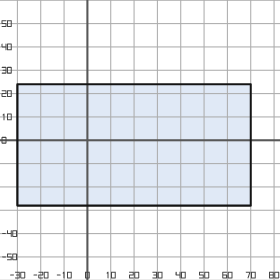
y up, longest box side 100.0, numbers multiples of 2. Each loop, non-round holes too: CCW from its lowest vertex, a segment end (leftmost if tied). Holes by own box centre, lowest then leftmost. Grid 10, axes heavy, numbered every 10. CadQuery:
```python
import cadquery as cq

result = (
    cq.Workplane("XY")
    .moveTo(-30.0, -28.0)
    .lineTo(70.0, -28.0)
    .lineTo(70.0, 24.0)
    .lineTo(-30.0, 24.0)
    .close()
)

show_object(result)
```